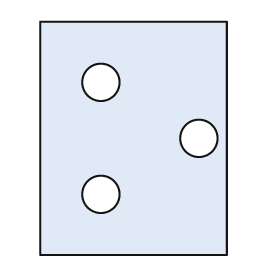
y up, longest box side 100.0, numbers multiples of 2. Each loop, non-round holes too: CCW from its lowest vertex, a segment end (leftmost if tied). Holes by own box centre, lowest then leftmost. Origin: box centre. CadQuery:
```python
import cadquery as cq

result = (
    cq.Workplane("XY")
    .moveTo(-40.0, -50.0)
    .lineTo(40.0, -50.0)
    .lineTo(40.0, 50.0)
    .lineTo(-40.0, 50.0)
    .close()
    .moveTo(-14.0, -24.0)
    .circle(8.0)
    .moveTo(28.0, 0.0)
    .circle(8.0)
    .moveTo(-14.0, 24.0)
    .circle(8.0)
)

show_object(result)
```